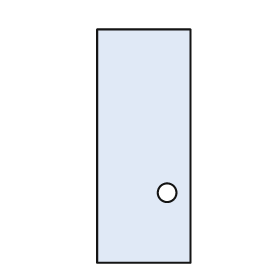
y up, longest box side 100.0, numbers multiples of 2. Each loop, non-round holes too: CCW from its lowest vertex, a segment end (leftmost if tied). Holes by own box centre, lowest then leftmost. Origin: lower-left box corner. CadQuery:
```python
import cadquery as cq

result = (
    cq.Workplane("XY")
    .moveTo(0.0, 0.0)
    .lineTo(40.0, 0.0)
    .lineTo(40.0, 100.0)
    .lineTo(0.0, 100.0)
    .close()
    .moveTo(30.0, 30.0)
    .circle(4.0)
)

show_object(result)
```